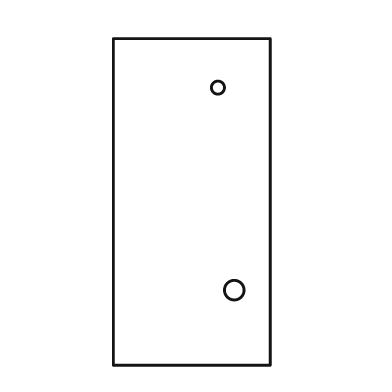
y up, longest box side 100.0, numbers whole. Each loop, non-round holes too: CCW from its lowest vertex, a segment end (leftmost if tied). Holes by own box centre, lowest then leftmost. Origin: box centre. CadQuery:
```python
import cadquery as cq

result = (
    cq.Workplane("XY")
    .moveTo(-24.0, -50.0)
    .lineTo(24.0, -50.0)
    .lineTo(24.0, 50.0)
    .lineTo(-24.0, 50.0)
    .close()
    .moveTo(13.0, -27.0)
    .circle(3.0)
    .moveTo(8.0, 35.0)
    .circle(2.0)
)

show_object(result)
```